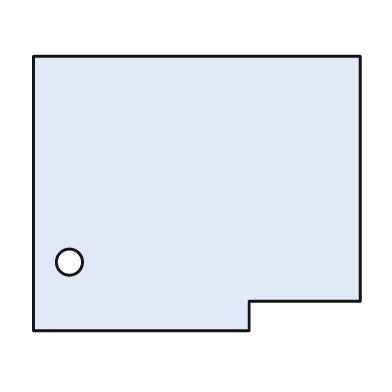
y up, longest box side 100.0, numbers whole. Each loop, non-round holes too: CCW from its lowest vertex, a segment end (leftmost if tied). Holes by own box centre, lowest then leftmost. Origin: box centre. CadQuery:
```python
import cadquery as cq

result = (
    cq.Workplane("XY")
    .moveTo(-50.0, -42.0)
    .lineTo(16.0, -42.0)
    .lineTo(16.0, -33.0)
    .lineTo(50.0, -33.0)
    .lineTo(50.0, 42.0)
    .lineTo(-50.0, 42.0)
    .close()
    .moveTo(-39.0, -21.0)
    .circle(4.0)
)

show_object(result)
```